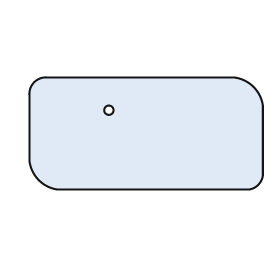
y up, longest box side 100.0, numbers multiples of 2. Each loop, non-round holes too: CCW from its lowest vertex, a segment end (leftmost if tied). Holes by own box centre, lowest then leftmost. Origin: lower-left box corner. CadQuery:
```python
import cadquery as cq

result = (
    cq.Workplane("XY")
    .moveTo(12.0, 0.0)
    .lineTo(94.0, 0.0)
    .threePointArc((98.0, 2.0), (100.0, 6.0))
    .lineTo(100.0, 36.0)
    .threePointArc((96.0, 44.0), (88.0, 48.0))
    .lineTo(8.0, 48.0)
    .threePointArc((2.0, 46.0), (0.0, 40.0))
    .lineTo(0.0, 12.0)
    .threePointArc((4.0, 4.0), (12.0, 0.0))
    .close()
    .moveTo(34.0, 34.0)
    .circle(2.0)
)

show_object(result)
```